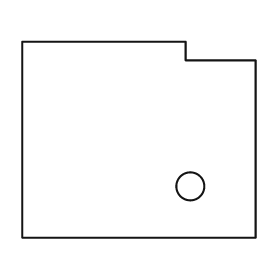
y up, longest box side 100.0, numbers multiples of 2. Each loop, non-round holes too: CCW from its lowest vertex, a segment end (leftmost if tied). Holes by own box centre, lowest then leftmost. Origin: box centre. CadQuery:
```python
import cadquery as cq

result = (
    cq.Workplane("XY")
    .moveTo(-50.0, -42.0)
    .lineTo(50.0, -42.0)
    .lineTo(50.0, 34.0)
    .lineTo(20.0, 34.0)
    .lineTo(20.0, 42.0)
    .lineTo(-50.0, 42.0)
    .close()
    .moveTo(22.0, -20.0)
    .circle(6.0)
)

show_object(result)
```